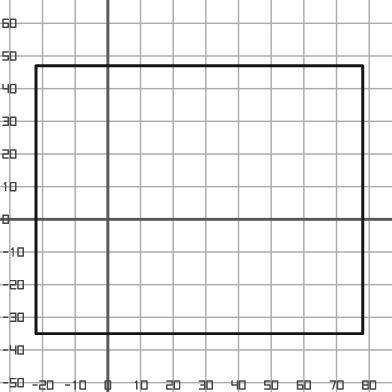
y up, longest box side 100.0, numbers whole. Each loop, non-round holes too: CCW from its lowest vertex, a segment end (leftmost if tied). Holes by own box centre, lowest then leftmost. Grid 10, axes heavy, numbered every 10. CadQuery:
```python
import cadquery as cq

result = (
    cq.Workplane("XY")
    .moveTo(-22.0, -35.0)
    .lineTo(78.0, -35.0)
    .lineTo(78.0, 47.0)
    .lineTo(-22.0, 47.0)
    .close()
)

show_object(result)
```